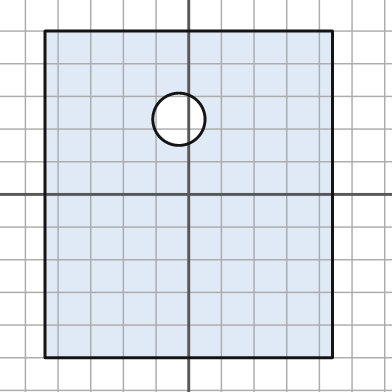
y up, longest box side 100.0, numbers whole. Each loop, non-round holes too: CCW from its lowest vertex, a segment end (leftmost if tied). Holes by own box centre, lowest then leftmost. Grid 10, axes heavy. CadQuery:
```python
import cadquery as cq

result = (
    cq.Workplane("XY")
    .moveTo(-44.0, -50.0)
    .lineTo(44.0, -50.0)
    .lineTo(44.0, 50.0)
    .lineTo(-44.0, 50.0)
    .close()
    .moveTo(-3.0, 23.0)
    .circle(8.0)
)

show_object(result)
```